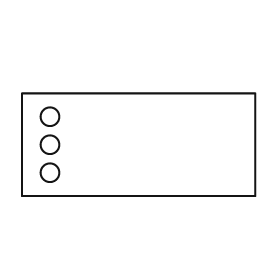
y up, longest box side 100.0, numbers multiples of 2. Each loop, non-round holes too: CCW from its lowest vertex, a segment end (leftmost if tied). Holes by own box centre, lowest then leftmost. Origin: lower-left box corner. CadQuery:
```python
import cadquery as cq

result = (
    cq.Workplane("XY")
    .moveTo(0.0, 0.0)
    .lineTo(100.0, 0.0)
    .lineTo(100.0, 44.0)
    .lineTo(0.0, 44.0)
    .close()
    .moveTo(12.0, 10.0)
    .circle(4.0)
    .moveTo(12.0, 22.0)
    .circle(4.0)
    .moveTo(12.0, 34.0)
    .circle(4.0)
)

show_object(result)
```